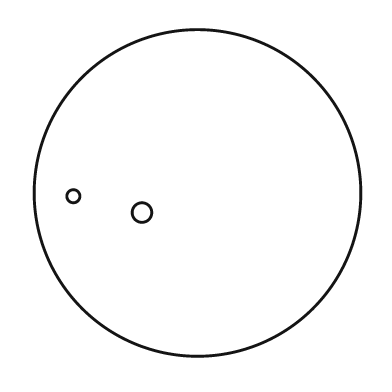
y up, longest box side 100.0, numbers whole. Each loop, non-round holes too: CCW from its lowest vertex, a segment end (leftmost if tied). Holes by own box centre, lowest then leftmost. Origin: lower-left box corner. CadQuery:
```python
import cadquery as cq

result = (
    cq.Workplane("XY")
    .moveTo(50.0, 50.0)
    .circle(50.0)
    .moveTo(33.0, 44.0)
    .circle(3.0)
    .moveTo(12.0, 49.0)
    .circle(2.0)
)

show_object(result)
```